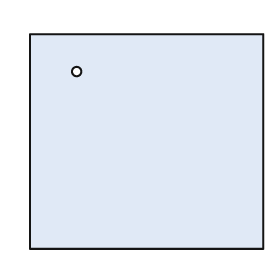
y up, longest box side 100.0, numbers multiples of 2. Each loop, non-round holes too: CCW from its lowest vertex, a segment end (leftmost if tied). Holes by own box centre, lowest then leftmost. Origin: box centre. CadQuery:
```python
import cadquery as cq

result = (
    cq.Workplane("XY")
    .moveTo(-50.0, -46.0)
    .lineTo(50.0, -46.0)
    .lineTo(50.0, 46.0)
    .lineTo(-50.0, 46.0)
    .close()
    .moveTo(-30.0, 30.0)
    .circle(2.0)
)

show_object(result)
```